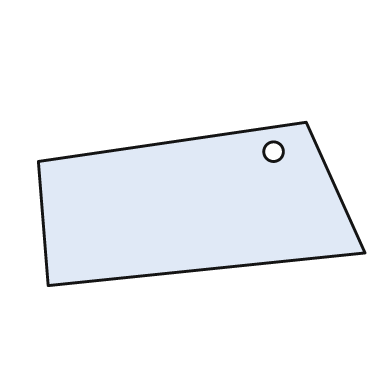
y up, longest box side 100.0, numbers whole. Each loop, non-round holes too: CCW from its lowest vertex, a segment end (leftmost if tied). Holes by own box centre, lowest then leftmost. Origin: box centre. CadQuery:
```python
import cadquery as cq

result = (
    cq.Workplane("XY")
    .moveTo(-47.0, -25.0)
    .lineTo(50.0, -15.0)
    .lineTo(32.0, 25.0)
    .lineTo(-50.0, 13.0)
    .close()
    .moveTo(22.0, 16.0)
    .circle(3.0)
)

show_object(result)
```